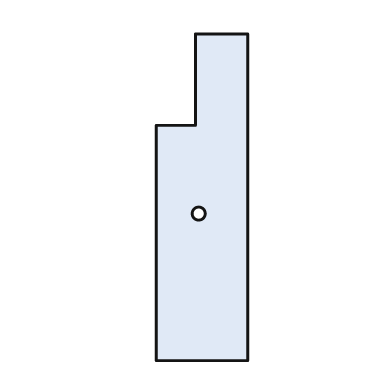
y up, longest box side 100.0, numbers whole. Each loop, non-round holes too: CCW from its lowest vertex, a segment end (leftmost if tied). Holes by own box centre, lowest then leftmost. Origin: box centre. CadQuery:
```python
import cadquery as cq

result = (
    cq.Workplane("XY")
    .moveTo(-14.0, -50.0)
    .lineTo(14.0, -50.0)
    .lineTo(14.0, 50.0)
    .lineTo(-2.0, 50.0)
    .lineTo(-2.0, 22.0)
    .lineTo(-14.0, 22.0)
    .close()
    .moveTo(-1.0, -5.0)
    .circle(2.0)
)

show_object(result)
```